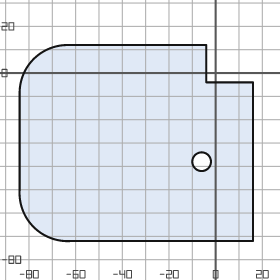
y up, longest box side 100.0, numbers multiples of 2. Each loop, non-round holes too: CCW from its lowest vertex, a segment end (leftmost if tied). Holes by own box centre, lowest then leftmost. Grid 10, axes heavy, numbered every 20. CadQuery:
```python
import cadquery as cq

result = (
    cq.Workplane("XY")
    .moveTo(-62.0, -72.0)
    .lineTo(16.0, -72.0)
    .lineTo(16.0, -4.0)
    .lineTo(-4.0, -4.0)
    .lineTo(-4.0, 12.0)
    .lineTo(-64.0, 12.0)
    .threePointArc((-78.0, 6.0), (-84.0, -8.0))
    .lineTo(-84.0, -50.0)
    .threePointArc((-78.0, -66.0), (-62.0, -72.0))
    .close()
    .moveTo(-6.0, -38.0)
    .circle(4.0)
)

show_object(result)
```